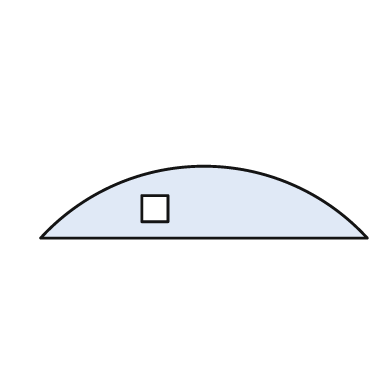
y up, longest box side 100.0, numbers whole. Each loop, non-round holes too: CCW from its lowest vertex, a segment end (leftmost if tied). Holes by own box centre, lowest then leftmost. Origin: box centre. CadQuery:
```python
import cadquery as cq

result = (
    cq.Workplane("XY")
    .moveTo(-50.0, -11.0)
    .lineTo(50.0, -11.0)
    .threePointArc((0.0, 11.0), (-50.0, -11.0))
    .close()
    .moveTo(-19.0, -6.0)
    .lineTo(-11.0, -6.0)
    .lineTo(-11.0, 2.0)
    .lineTo(-19.0, 2.0)
    .close()
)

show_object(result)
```